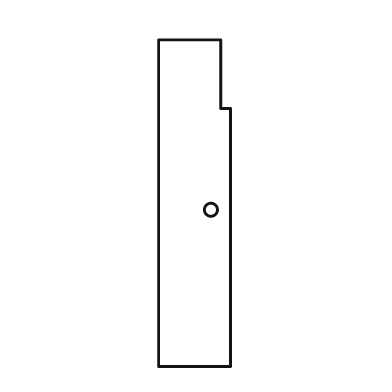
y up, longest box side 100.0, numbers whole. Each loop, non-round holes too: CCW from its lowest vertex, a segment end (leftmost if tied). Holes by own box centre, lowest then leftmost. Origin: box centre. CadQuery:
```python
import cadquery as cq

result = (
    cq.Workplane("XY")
    .moveTo(-11.0, -50.0)
    .lineTo(11.0, -50.0)
    .lineTo(11.0, 29.0)
    .lineTo(8.0, 29.0)
    .lineTo(8.0, 50.0)
    .lineTo(-11.0, 50.0)
    .close()
    .moveTo(5.0, -2.0)
    .circle(2.0)
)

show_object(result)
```